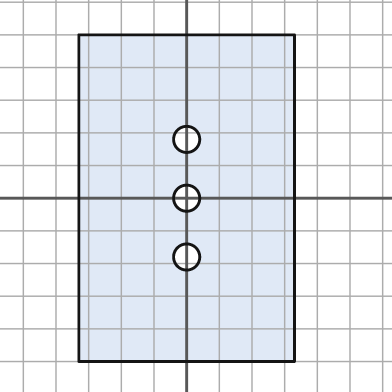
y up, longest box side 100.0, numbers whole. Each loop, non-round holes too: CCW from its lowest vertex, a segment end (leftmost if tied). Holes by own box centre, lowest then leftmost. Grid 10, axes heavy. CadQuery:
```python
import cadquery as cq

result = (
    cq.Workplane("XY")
    .moveTo(-33.0, -50.0)
    .lineTo(33.0, -50.0)
    .lineTo(33.0, 50.0)
    .lineTo(-33.0, 50.0)
    .close()
    .moveTo(0.0, -18.0)
    .circle(4.0)
    .moveTo(0.0, 0.0)
    .circle(4.0)
    .moveTo(0.0, 18.0)
    .circle(4.0)
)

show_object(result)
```